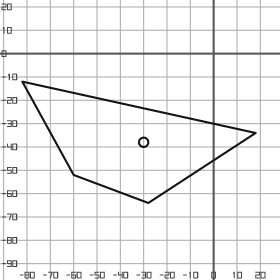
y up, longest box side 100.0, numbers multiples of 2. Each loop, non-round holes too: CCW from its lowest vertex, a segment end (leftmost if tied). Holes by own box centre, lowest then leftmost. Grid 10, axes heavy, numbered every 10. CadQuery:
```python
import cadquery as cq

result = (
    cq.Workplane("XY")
    .moveTo(-28.0, -64.0)
    .lineTo(18.0, -34.0)
    .lineTo(-82.0, -12.0)
    .lineTo(-60.0, -52.0)
    .close()
    .moveTo(-30.0, -38.0)
    .circle(2.0)
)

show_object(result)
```